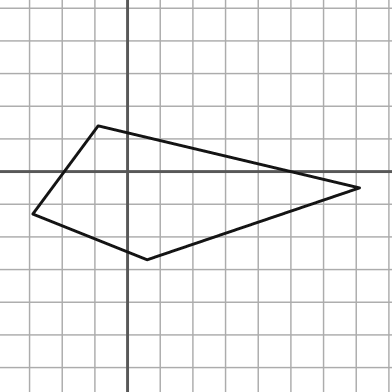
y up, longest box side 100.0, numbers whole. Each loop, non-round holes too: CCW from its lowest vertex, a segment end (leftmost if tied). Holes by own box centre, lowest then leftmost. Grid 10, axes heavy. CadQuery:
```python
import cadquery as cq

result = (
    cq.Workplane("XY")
    .moveTo(6.0, -27.0)
    .lineTo(71.0, -5.0)
    .lineTo(-9.0, 14.0)
    .lineTo(-29.0, -13.0)
    .close()
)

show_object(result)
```